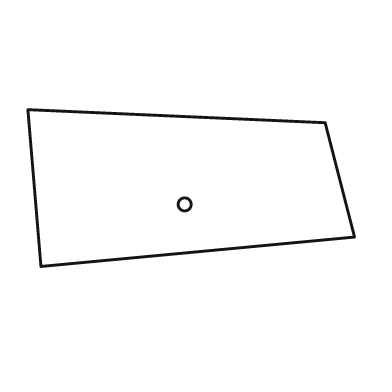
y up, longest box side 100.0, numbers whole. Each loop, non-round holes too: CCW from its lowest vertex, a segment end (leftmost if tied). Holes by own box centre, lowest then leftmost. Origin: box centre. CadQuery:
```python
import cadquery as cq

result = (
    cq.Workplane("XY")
    .moveTo(-46.0, -24.0)
    .lineTo(50.0, -15.0)
    .lineTo(41.0, 20.0)
    .lineTo(-50.0, 24.0)
    .close()
    .moveTo(-2.0, -5.0)
    .circle(2.0)
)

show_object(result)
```